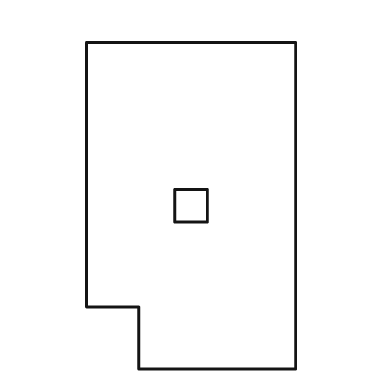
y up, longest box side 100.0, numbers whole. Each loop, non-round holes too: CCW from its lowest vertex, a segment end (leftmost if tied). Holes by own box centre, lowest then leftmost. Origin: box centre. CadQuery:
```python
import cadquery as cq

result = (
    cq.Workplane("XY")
    .moveTo(-16.0, -50.0)
    .lineTo(32.0, -50.0)
    .lineTo(32.0, 50.0)
    .lineTo(-32.0, 50.0)
    .lineTo(-32.0, -31.0)
    .lineTo(-16.0, -31.0)
    .close()
    .moveTo(-5.0, -5.0)
    .lineTo(5.0, -5.0)
    .lineTo(5.0, 5.0)
    .lineTo(-5.0, 5.0)
    .close()
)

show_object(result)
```